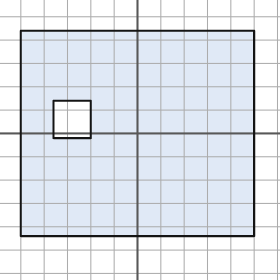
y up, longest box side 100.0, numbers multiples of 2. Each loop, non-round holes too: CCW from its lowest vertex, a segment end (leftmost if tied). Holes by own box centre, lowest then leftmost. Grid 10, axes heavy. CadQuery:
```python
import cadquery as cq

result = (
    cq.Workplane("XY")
    .moveTo(-50.0, -44.0)
    .lineTo(50.0, -44.0)
    .lineTo(50.0, 44.0)
    .lineTo(-50.0, 44.0)
    .close()
    .moveTo(-36.0, -2.0)
    .lineTo(-20.0, -2.0)
    .lineTo(-20.0, 14.0)
    .lineTo(-36.0, 14.0)
    .close()
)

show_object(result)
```